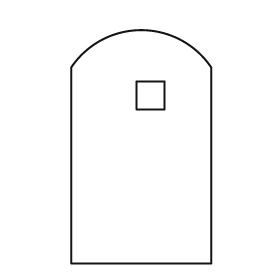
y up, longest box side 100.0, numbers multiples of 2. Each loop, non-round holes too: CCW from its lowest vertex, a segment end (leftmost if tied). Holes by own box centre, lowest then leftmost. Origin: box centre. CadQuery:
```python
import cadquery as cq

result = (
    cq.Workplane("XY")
    .moveTo(-30.0, -50.0)
    .lineTo(30.0, -50.0)
    .lineTo(30.0, 34.0)
    .threePointArc((0.0, 50.0), (-30.0, 34.0))
    .close()
    .moveTo(-2.0, 16.0)
    .lineTo(10.0, 16.0)
    .lineTo(10.0, 28.0)
    .lineTo(-2.0, 28.0)
    .close()
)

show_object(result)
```